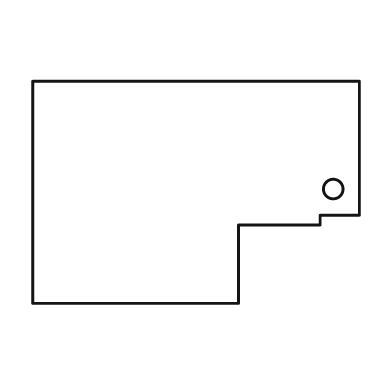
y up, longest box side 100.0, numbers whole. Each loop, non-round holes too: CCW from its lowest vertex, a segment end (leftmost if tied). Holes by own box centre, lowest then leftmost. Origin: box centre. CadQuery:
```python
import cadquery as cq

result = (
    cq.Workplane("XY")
    .moveTo(-50.0, -34.0)
    .lineTo(13.0, -34.0)
    .lineTo(13.0, -10.0)
    .lineTo(38.0, -10.0)
    .lineTo(38.0, -7.0)
    .lineTo(50.0, -7.0)
    .lineTo(50.0, 34.0)
    .lineTo(-50.0, 34.0)
    .close()
    .moveTo(42.0, 1.0)
    .circle(3.0)
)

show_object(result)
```